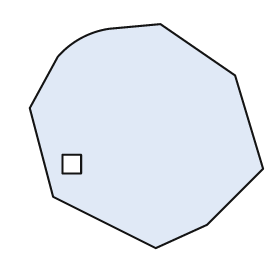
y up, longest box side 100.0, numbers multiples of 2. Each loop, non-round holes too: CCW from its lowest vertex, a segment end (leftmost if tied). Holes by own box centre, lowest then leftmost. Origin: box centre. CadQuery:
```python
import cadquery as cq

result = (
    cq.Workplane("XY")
    .moveTo(4.0, -48.0)
    .lineTo(26.0, -38.0)
    .lineTo(50.0, -14.0)
    .lineTo(38.0, 26.0)
    .lineTo(6.0, 48.0)
    .lineTo(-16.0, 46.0)
    .threePointArc((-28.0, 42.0), (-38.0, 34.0))
    .lineTo(-50.0, 12.0)
    .lineTo(-40.0, -26.0)
    .close()
    .moveTo(-36.0, -16.0)
    .lineTo(-28.0, -16.0)
    .lineTo(-28.0, -8.0)
    .lineTo(-36.0, -8.0)
    .close()
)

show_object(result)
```